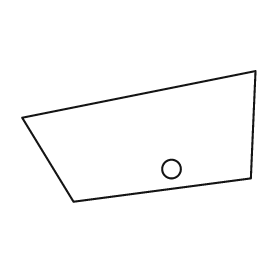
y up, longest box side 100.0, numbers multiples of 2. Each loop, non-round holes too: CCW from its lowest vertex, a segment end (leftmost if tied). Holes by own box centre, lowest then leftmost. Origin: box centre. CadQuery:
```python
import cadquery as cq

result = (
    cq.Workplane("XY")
    .moveTo(-28.0, -28.0)
    .lineTo(48.0, -18.0)
    .lineTo(50.0, 28.0)
    .lineTo(-50.0, 8.0)
    .close()
    .moveTo(14.0, -14.0)
    .circle(4.0)
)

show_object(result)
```